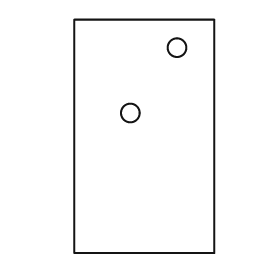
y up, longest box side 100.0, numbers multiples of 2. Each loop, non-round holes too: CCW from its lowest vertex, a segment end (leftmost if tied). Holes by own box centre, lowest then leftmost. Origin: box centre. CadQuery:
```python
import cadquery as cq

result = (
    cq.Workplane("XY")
    .moveTo(-30.0, -50.0)
    .lineTo(30.0, -50.0)
    .lineTo(30.0, 50.0)
    .lineTo(-30.0, 50.0)
    .close()
    .moveTo(-6.0, 10.0)
    .circle(4.0)
    .moveTo(14.0, 38.0)
    .circle(4.0)
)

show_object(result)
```